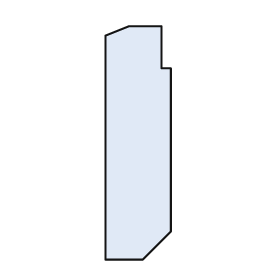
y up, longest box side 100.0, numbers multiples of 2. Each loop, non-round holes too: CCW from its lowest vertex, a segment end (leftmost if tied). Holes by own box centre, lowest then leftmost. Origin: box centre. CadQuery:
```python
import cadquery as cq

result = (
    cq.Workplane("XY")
    .moveTo(-14.0, -50.0)
    .lineTo(2.0, -50.0)
    .lineTo(14.0, -38.0)
    .lineTo(14.0, 32.0)
    .lineTo(10.0, 32.0)
    .lineTo(10.0, 50.0)
    .lineTo(-4.0, 50.0)
    .lineTo(-14.0, 46.0)
    .close()
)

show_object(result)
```